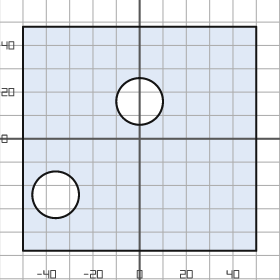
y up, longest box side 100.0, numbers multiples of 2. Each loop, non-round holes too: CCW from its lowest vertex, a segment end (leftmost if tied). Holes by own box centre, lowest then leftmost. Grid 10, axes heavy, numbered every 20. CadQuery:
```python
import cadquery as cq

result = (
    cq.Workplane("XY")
    .moveTo(-50.0, -48.0)
    .lineTo(50.0, -48.0)
    .lineTo(50.0, 48.0)
    .lineTo(-50.0, 48.0)
    .close()
    .moveTo(-36.0, -24.0)
    .circle(10.0)
    .moveTo(0.0, 16.0)
    .circle(10.0)
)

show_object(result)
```